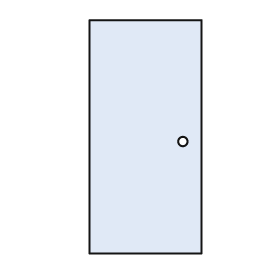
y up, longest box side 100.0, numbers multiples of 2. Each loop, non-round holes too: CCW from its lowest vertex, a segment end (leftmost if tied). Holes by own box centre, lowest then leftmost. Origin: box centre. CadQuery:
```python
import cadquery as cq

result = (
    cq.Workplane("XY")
    .moveTo(-24.0, -50.0)
    .lineTo(24.0, -50.0)
    .lineTo(24.0, 50.0)
    .lineTo(-24.0, 50.0)
    .close()
    .moveTo(16.0, -2.0)
    .circle(2.0)
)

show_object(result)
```